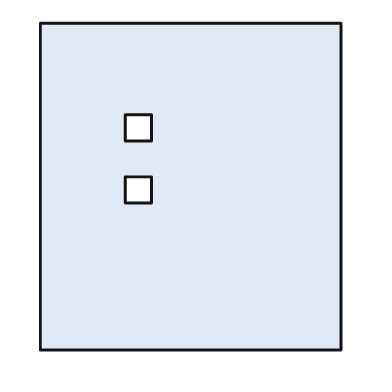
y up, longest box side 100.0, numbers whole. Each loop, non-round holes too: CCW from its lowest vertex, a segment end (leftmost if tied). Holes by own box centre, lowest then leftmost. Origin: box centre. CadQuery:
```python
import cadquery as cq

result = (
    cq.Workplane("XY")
    .moveTo(-46.0, -50.0)
    .lineTo(46.0, -50.0)
    .lineTo(46.0, 50.0)
    .lineTo(-46.0, 50.0)
    .close()
    .moveTo(-20.0, -5.0)
    .lineTo(-12.0, -5.0)
    .lineTo(-12.0, 3.0)
    .lineTo(-20.0, 3.0)
    .close()
    .moveTo(-20.0, 14.0)
    .lineTo(-12.0, 14.0)
    .lineTo(-12.0, 22.0)
    .lineTo(-20.0, 22.0)
    .close()
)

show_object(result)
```